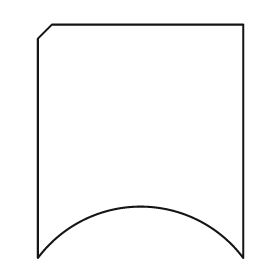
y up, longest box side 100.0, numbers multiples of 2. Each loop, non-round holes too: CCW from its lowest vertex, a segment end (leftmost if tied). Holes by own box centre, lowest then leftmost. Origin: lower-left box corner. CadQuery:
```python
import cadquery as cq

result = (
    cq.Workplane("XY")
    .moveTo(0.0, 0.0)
    .threePointArc((44.0, 22.0), (88.0, 0.0))
    .lineTo(88.0, 100.0)
    .lineTo(6.0, 100.0)
    .lineTo(0.0, 94.0)
    .close()
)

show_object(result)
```